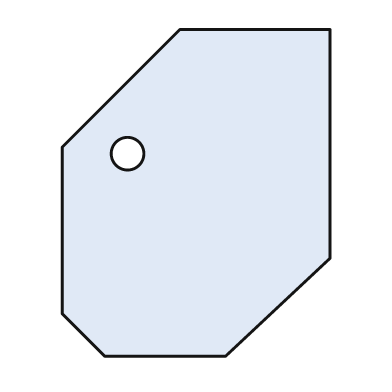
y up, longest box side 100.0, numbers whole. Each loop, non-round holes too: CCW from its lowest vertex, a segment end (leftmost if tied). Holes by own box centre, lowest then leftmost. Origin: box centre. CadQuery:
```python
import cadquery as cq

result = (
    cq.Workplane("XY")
    .moveTo(-28.0, -50.0)
    .lineTo(9.0, -50.0)
    .lineTo(41.0, -20.0)
    .lineTo(41.0, 50.0)
    .lineTo(-5.0, 50.0)
    .lineTo(-41.0, 14.0)
    .lineTo(-41.0, -37.0)
    .close()
    .moveTo(-21.0, 12.0)
    .circle(5.0)
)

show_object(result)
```